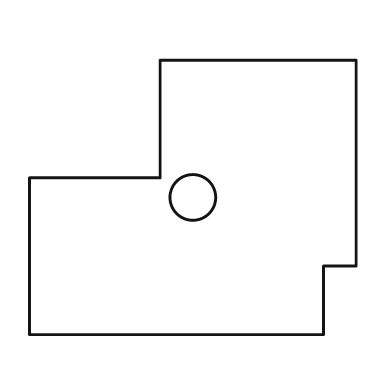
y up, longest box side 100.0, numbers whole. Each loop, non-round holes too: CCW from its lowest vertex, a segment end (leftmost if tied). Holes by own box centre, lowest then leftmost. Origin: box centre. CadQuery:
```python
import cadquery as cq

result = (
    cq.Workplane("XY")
    .moveTo(-50.0, -42.0)
    .lineTo(40.0, -42.0)
    .lineTo(40.0, -21.0)
    .lineTo(50.0, -21.0)
    .lineTo(50.0, 42.0)
    .lineTo(-10.0, 42.0)
    .lineTo(-10.0, 6.0)
    .lineTo(-50.0, 6.0)
    .close()
    .moveTo(0.0, 0.0)
    .circle(7.0)
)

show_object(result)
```